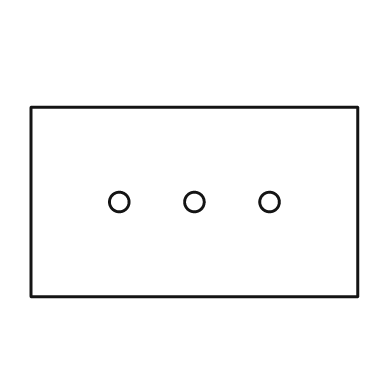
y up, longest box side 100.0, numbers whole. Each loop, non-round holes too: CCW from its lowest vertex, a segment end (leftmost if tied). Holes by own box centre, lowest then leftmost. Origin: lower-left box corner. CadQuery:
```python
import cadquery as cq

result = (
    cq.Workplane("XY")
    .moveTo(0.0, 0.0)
    .lineTo(100.0, 0.0)
    .lineTo(100.0, 58.0)
    .lineTo(0.0, 58.0)
    .close()
    .moveTo(27.0, 29.0)
    .circle(3.0)
    .moveTo(50.0, 29.0)
    .circle(3.0)
    .moveTo(73.0, 29.0)
    .circle(3.0)
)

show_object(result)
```